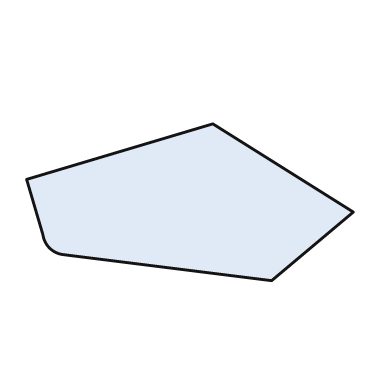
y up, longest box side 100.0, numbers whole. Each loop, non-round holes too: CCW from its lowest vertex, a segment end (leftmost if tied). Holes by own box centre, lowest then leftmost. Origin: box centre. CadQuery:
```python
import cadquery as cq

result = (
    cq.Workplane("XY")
    .moveTo(25.0, -24.0)
    .lineTo(50.0, -3.0)
    .lineTo(7.0, 24.0)
    .lineTo(-50.0, 7.0)
    .lineTo(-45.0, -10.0)
    .threePointArc((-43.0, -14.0), (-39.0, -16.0))
    .close()
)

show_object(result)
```